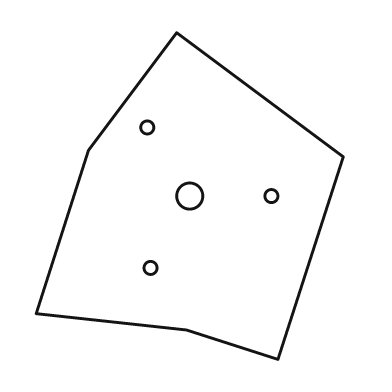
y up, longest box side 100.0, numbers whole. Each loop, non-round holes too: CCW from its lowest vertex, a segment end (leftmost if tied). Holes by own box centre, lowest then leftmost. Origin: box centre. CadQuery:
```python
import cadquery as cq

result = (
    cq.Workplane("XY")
    .moveTo(27.0, -50.0)
    .lineTo(47.0, 12.0)
    .lineTo(-4.0, 50.0)
    .lineTo(-31.0, 14.0)
    .lineTo(-47.0, -36.0)
    .lineTo(-1.0, -41.0)
    .close()
    .moveTo(-12.0, -22.0)
    .circle(2.0)
    .moveTo(0.0, 0.0)
    .circle(4.0)
    .moveTo(25.0, 0.0)
    .circle(2.0)
    .moveTo(-13.0, 21.0)
    .circle(2.0)
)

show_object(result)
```